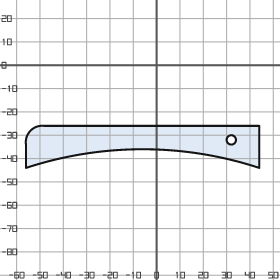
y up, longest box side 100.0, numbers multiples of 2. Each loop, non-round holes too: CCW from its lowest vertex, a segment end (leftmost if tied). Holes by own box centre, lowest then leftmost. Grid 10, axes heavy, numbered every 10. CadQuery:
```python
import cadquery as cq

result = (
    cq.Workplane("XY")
    .moveTo(-56.0, -44.0)
    .threePointArc((-6.0, -36.0), (44.0, -44.0))
    .lineTo(44.0, -26.0)
    .lineTo(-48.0, -26.0)
    .threePointArc((-54.0, -28.0), (-56.0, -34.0))
    .close()
    .moveTo(32.0, -32.0)
    .circle(2.0)
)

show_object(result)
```